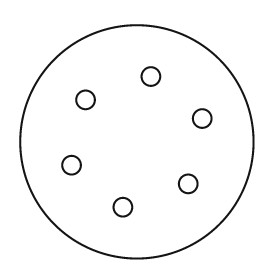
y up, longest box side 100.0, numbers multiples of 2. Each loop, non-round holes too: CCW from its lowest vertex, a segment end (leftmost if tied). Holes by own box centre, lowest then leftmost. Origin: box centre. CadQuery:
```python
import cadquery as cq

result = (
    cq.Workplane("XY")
    .moveTo(0.0, 0.0)
    .circle(50.0)
    .moveTo(-6.0, -28.0)
    .circle(4.0)
    .moveTo(22.0, -18.0)
    .circle(4.0)
    .moveTo(-28.0, -10.0)
    .circle(4.0)
    .moveTo(28.0, 10.0)
    .circle(4.0)
    .moveTo(-22.0, 18.0)
    .circle(4.0)
    .moveTo(6.0, 28.0)
    .circle(4.0)
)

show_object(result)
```